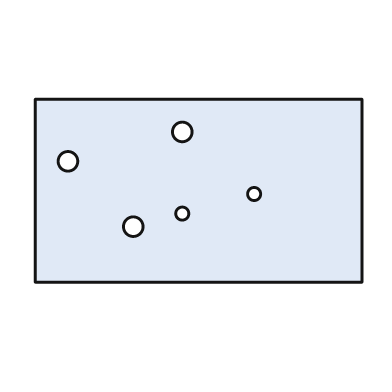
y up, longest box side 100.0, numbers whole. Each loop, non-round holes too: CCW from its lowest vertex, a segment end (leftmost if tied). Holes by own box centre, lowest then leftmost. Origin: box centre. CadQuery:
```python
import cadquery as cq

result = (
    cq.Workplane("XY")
    .moveTo(-50.0, -28.0)
    .lineTo(50.0, -28.0)
    .lineTo(50.0, 28.0)
    .lineTo(-50.0, 28.0)
    .close()
    .moveTo(-20.0, -11.0)
    .circle(3.0)
    .moveTo(-5.0, -7.0)
    .circle(2.0)
    .moveTo(17.0, -1.0)
    .circle(2.0)
    .moveTo(-40.0, 9.0)
    .circle(3.0)
    .moveTo(-5.0, 18.0)
    .circle(3.0)
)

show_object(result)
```